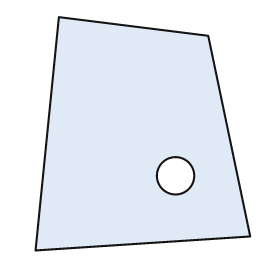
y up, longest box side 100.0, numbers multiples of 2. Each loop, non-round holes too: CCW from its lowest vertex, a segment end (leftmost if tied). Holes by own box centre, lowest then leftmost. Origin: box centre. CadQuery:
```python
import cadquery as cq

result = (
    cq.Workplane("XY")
    .moveTo(-46.0, -50.0)
    .lineTo(46.0, -44.0)
    .lineTo(28.0, 42.0)
    .lineTo(-36.0, 50.0)
    .close()
    .moveTo(14.0, -18.0)
    .circle(8.0)
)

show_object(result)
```